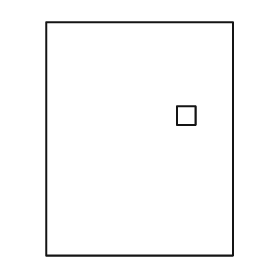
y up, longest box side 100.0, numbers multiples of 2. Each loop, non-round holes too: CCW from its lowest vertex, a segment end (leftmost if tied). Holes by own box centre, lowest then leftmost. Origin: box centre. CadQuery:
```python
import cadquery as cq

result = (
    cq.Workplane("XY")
    .moveTo(-40.0, -50.0)
    .lineTo(40.0, -50.0)
    .lineTo(40.0, 50.0)
    .lineTo(-40.0, 50.0)
    .close()
    .moveTo(16.0, 6.0)
    .lineTo(24.0, 6.0)
    .lineTo(24.0, 14.0)
    .lineTo(16.0, 14.0)
    .close()
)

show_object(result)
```